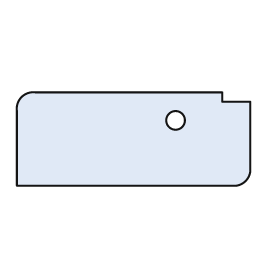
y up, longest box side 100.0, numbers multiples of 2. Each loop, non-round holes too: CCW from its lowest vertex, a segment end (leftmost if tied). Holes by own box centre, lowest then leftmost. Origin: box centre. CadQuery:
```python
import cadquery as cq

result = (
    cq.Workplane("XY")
    .moveTo(-50.0, -20.0)
    .lineTo(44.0, -20.0)
    .threePointArc((48.0, -18.0), (50.0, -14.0))
    .lineTo(50.0, 16.0)
    .lineTo(38.0, 16.0)
    .lineTo(38.0, 20.0)
    .lineTo(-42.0, 20.0)
    .threePointArc((-48.0, 18.0), (-50.0, 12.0))
    .close()
    .moveTo(18.0, 8.0)
    .circle(4.0)
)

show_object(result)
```